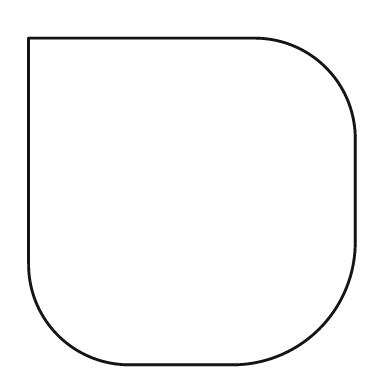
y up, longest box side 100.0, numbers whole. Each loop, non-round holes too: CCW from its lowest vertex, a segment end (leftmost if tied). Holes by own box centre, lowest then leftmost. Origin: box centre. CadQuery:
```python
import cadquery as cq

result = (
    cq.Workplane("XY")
    .moveTo(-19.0, -50.0)
    .lineTo(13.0, -50.0)
    .threePointArc((39.0, -39.0), (50.0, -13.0))
    .lineTo(50.0, 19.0)
    .threePointArc((41.0, 41.0), (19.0, 50.0))
    .lineTo(-50.0, 50.0)
    .lineTo(-50.0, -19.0)
    .threePointArc((-41.0, -41.0), (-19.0, -50.0))
    .close()
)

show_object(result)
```